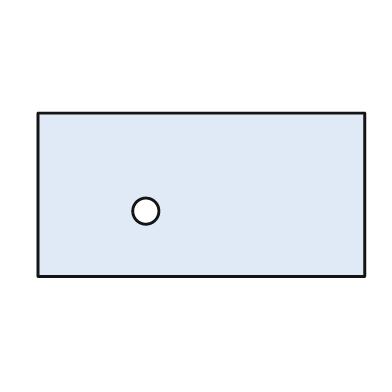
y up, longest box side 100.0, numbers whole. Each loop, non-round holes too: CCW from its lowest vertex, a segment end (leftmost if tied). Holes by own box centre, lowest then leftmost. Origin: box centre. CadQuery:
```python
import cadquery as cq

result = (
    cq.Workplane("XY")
    .moveTo(-50.0, -25.0)
    .lineTo(50.0, -25.0)
    .lineTo(50.0, 25.0)
    .lineTo(-50.0, 25.0)
    .close()
    .moveTo(-17.0, -5.0)
    .circle(4.0)
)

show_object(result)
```